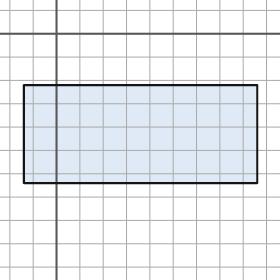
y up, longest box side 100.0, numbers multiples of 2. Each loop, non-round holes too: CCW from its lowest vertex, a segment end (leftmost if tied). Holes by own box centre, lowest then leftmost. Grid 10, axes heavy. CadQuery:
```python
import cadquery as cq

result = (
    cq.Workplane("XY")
    .moveTo(-14.0, -64.0)
    .lineTo(86.0, -64.0)
    .lineTo(86.0, -22.0)
    .lineTo(-14.0, -22.0)
    .close()
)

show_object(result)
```